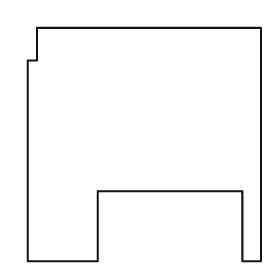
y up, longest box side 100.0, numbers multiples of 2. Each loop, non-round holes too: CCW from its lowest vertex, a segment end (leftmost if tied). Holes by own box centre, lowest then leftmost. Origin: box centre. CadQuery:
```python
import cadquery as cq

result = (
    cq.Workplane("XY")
    .moveTo(-50.0, -50.0)
    .lineTo(-20.0, -50.0)
    .lineTo(-20.0, -20.0)
    .lineTo(42.0, -20.0)
    .lineTo(42.0, -50.0)
    .lineTo(50.0, -50.0)
    .lineTo(50.0, 50.0)
    .lineTo(-46.0, 50.0)
    .lineTo(-46.0, 36.0)
    .lineTo(-50.0, 36.0)
    .close()
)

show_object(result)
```